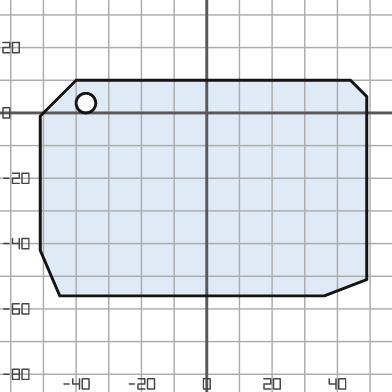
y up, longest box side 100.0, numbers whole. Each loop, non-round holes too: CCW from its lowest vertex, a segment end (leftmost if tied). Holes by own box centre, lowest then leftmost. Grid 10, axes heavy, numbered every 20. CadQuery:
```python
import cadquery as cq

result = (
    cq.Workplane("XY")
    .moveTo(-45.0, -56.0)
    .lineTo(36.0, -56.0)
    .lineTo(49.0, -51.0)
    .lineTo(49.0, 5.0)
    .lineTo(44.0, 10.0)
    .lineTo(-40.0, 10.0)
    .lineTo(-51.0, -1.0)
    .lineTo(-51.0, -42.0)
    .close()
    .moveTo(-37.0, 3.0)
    .circle(3.0)
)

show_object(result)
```